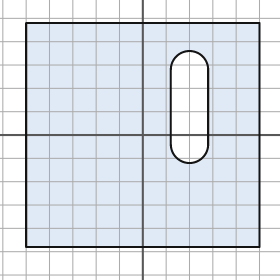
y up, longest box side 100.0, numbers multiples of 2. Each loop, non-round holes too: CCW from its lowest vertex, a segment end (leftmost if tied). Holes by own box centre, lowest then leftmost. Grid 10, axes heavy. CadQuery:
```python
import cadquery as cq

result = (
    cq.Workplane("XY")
    .moveTo(-50.0, -48.0)
    .lineTo(50.0, -48.0)
    .lineTo(50.0, 48.0)
    .lineTo(-50.0, 48.0)
    .close()
    .moveTo(12.0, -4.0)
    .threePointArc((20.0, -12.0), (28.0, -4.0))
    .lineTo(28.0, 28.0)
    .threePointArc((20.0, 36.0), (12.0, 28.0))
    .close()
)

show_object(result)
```